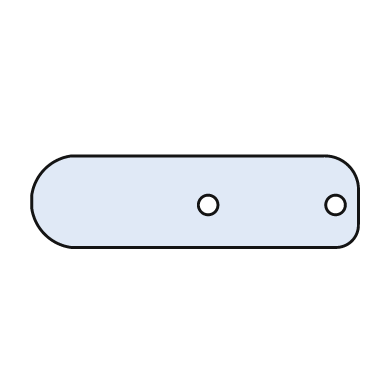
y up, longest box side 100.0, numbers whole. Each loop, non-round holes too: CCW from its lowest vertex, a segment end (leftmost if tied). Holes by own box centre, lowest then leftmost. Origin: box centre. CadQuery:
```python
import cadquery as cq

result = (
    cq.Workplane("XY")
    .moveTo(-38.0, -14.0)
    .lineTo(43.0, -14.0)
    .threePointArc((48.0, -12.0), (50.0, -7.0))
    .lineTo(50.0, 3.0)
    .threePointArc((47.0, 11.0), (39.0, 14.0))
    .lineTo(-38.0, 14.0)
    .threePointArc((-46.0, 10.0), (-50.0, 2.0))
    .lineTo(-50.0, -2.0)
    .threePointArc((-46.0, -10.0), (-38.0, -14.0))
    .close()
    .moveTo(4.0, -1.0)
    .circle(3.0)
    .moveTo(43.0, -1.0)
    .circle(3.0)
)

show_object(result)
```